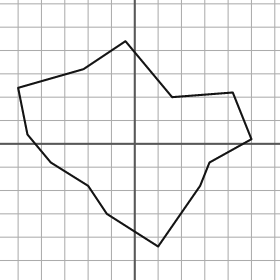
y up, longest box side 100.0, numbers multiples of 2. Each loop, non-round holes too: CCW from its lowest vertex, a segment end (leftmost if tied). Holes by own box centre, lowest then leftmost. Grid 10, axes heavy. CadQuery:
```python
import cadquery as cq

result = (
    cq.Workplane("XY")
    .moveTo(10.0, -44.0)
    .lineTo(28.0, -18.0)
    .lineTo(32.0, -8.0)
    .lineTo(50.0, 2.0)
    .lineTo(42.0, 22.0)
    .lineTo(16.0, 20.0)
    .lineTo(-4.0, 44.0)
    .lineTo(-22.0, 32.0)
    .lineTo(-50.0, 24.0)
    .lineTo(-46.0, 4.0)
    .lineTo(-36.0, -8.0)
    .lineTo(-20.0, -18.0)
    .lineTo(-12.0, -30.0)
    .close()
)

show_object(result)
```